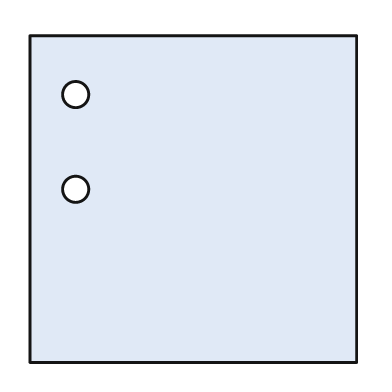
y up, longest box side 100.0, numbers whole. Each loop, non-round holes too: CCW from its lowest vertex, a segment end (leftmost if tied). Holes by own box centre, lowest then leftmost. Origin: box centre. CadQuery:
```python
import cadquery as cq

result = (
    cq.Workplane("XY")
    .moveTo(-50.0, -50.0)
    .lineTo(50.0, -50.0)
    .lineTo(50.0, 50.0)
    .lineTo(-50.0, 50.0)
    .close()
    .moveTo(-36.0, 3.0)
    .circle(4.0)
    .moveTo(-36.0, 32.0)
    .circle(4.0)
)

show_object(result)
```